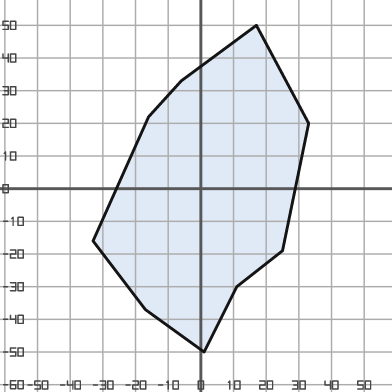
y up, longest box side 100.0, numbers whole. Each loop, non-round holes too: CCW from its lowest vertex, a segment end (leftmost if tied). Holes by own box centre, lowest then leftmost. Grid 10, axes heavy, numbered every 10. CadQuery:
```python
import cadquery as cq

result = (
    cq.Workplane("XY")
    .moveTo(1.0, -50.0)
    .lineTo(11.0, -30.0)
    .lineTo(25.0, -19.0)
    .lineTo(33.0, 20.0)
    .lineTo(17.0, 50.0)
    .lineTo(-6.0, 33.0)
    .lineTo(-16.0, 22.0)
    .lineTo(-33.0, -16.0)
    .lineTo(-17.0, -37.0)
    .close()
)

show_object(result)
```